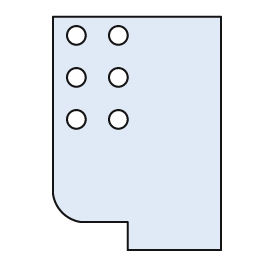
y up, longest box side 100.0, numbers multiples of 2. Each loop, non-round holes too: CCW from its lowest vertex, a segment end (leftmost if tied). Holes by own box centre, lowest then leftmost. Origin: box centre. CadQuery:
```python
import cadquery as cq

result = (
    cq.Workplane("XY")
    .moveTo(-4.0, -50.0)
    .lineTo(36.0, -50.0)
    .lineTo(36.0, 50.0)
    .lineTo(-36.0, 50.0)
    .lineTo(-36.0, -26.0)
    .threePointArc((-32.0, -34.0), (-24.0, -38.0))
    .lineTo(-4.0, -38.0)
    .close()
    .moveTo(-26.0, 6.0)
    .circle(4.0)
    .moveTo(-8.0, 6.0)
    .circle(4.0)
    .moveTo(-26.0, 24.0)
    .circle(4.0)
    .moveTo(-8.0, 24.0)
    .circle(4.0)
    .moveTo(-26.0, 42.0)
    .circle(4.0)
    .moveTo(-8.0, 42.0)
    .circle(4.0)
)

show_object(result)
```